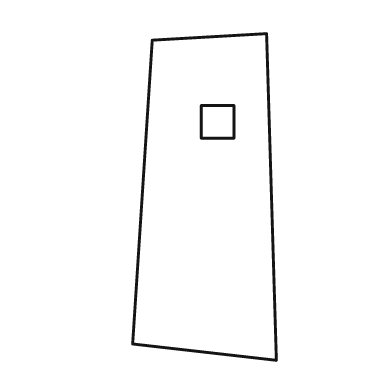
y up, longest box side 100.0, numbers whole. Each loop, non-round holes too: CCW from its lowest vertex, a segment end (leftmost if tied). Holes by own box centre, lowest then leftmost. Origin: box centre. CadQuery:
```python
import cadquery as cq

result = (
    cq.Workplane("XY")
    .moveTo(22.0, -50.0)
    .lineTo(19.0, 50.0)
    .lineTo(-16.0, 48.0)
    .lineTo(-22.0, -45.0)
    .close()
    .moveTo(-1.0, 18.0)
    .lineTo(9.0, 18.0)
    .lineTo(9.0, 28.0)
    .lineTo(-1.0, 28.0)
    .close()
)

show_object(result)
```